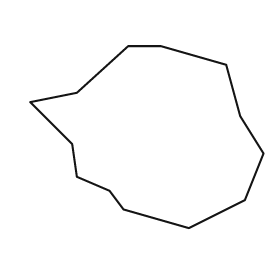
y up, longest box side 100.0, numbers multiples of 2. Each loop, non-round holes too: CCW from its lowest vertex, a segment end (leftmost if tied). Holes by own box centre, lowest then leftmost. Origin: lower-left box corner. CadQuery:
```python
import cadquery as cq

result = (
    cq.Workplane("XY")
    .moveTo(68.0, 0.0)
    .lineTo(92.0, 12.0)
    .lineTo(100.0, 32.0)
    .lineTo(90.0, 48.0)
    .lineTo(84.0, 70.0)
    .lineTo(56.0, 78.0)
    .lineTo(42.0, 78.0)
    .lineTo(20.0, 58.0)
    .lineTo(0.0, 54.0)
    .lineTo(18.0, 36.0)
    .lineTo(20.0, 22.0)
    .lineTo(34.0, 16.0)
    .lineTo(40.0, 8.0)
    .close()
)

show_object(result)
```